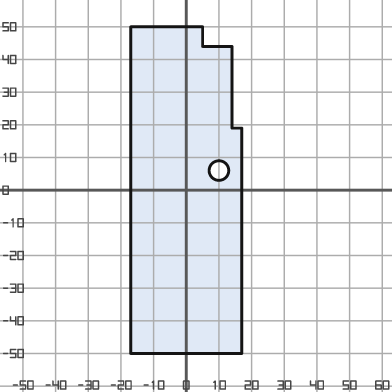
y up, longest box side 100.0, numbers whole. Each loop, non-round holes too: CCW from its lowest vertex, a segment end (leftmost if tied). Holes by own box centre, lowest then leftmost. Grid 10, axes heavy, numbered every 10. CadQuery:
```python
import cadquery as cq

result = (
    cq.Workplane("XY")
    .moveTo(-17.0, -50.0)
    .lineTo(17.0, -50.0)
    .lineTo(17.0, 19.0)
    .lineTo(14.0, 19.0)
    .lineTo(14.0, 44.0)
    .lineTo(5.0, 44.0)
    .lineTo(5.0, 50.0)
    .lineTo(-17.0, 50.0)
    .close()
    .moveTo(10.0, 6.0)
    .circle(3.0)
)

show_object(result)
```